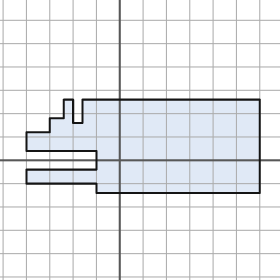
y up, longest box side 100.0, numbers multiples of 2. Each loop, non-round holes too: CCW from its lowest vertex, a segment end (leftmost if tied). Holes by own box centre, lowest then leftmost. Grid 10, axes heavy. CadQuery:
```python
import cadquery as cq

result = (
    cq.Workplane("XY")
    .moveTo(-10.0, -14.0)
    .lineTo(60.0, -14.0)
    .lineTo(60.0, 26.0)
    .lineTo(-16.0, 26.0)
    .lineTo(-16.0, 16.0)
    .lineTo(-20.0, 16.0)
    .lineTo(-20.0, 26.0)
    .lineTo(-24.0, 26.0)
    .lineTo(-24.0, 18.0)
    .lineTo(-30.0, 18.0)
    .lineTo(-30.0, 12.0)
    .lineTo(-40.0, 12.0)
    .lineTo(-40.0, 4.0)
    .lineTo(-10.0, 4.0)
    .lineTo(-10.0, -4.0)
    .lineTo(-40.0, -4.0)
    .lineTo(-40.0, -10.0)
    .lineTo(-10.0, -10.0)
    .close()
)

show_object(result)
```